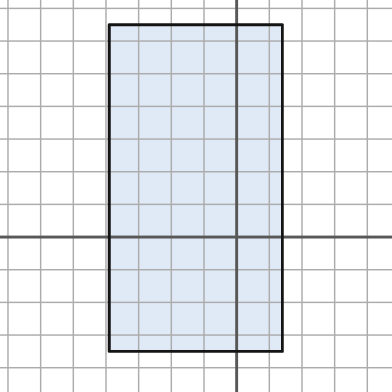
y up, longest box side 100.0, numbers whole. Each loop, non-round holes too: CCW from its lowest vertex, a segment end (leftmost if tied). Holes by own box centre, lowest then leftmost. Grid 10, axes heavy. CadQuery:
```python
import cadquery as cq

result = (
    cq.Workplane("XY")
    .moveTo(-39.0, -35.0)
    .lineTo(14.0, -35.0)
    .lineTo(14.0, 65.0)
    .lineTo(-39.0, 65.0)
    .close()
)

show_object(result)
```